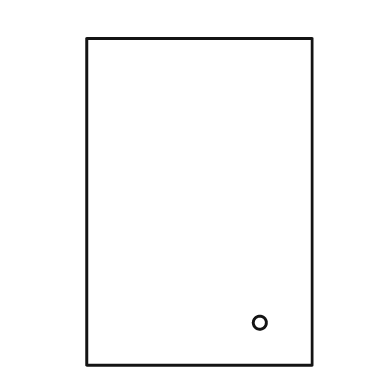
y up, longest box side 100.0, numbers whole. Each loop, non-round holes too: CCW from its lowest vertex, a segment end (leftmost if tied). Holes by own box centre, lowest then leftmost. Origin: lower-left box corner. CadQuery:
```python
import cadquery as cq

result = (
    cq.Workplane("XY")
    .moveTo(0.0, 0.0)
    .lineTo(69.0, 0.0)
    .lineTo(69.0, 100.0)
    .lineTo(0.0, 100.0)
    .close()
    .moveTo(53.0, 13.0)
    .circle(2.0)
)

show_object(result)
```